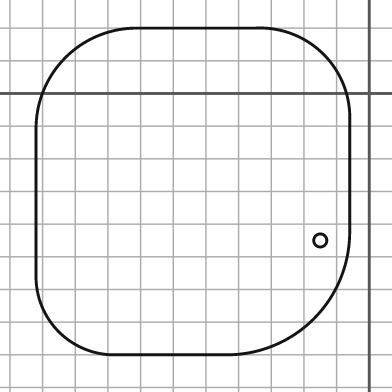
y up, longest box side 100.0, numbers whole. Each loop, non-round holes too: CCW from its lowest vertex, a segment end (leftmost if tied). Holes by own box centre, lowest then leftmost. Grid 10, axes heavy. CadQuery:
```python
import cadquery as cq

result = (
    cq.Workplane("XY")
    .moveTo(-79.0, -80.0)
    .lineTo(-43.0, -80.0)
    .threePointArc((-17.0, -69.0), (-6.0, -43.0))
    .lineTo(-6.0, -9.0)
    .threePointArc((-14.0, 12.0), (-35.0, 20.0))
    .lineTo(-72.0, 20.0)
    .threePointArc((-93.0, 11.0), (-102.0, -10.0))
    .lineTo(-102.0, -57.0)
    .threePointArc((-95.0, -73.0), (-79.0, -80.0))
    .close()
    .moveTo(-15.0, -45.0)
    .circle(2.0)
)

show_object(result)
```